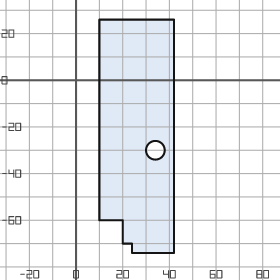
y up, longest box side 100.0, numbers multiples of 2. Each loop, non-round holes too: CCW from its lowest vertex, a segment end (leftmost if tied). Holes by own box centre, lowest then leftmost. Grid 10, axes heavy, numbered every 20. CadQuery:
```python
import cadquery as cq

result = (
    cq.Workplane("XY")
    .moveTo(24.0, -74.0)
    .lineTo(42.0, -74.0)
    .lineTo(42.0, 26.0)
    .lineTo(10.0, 26.0)
    .lineTo(10.0, -60.0)
    .lineTo(20.0, -60.0)
    .lineTo(20.0, -70.0)
    .lineTo(24.0, -70.0)
    .close()
    .moveTo(34.0, -30.0)
    .circle(4.0)
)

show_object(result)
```